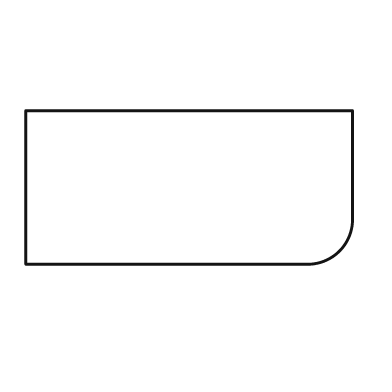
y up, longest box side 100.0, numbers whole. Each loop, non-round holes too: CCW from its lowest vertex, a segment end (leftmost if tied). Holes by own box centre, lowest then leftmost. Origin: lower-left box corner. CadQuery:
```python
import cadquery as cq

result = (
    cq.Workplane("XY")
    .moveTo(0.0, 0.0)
    .lineTo(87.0, 0.0)
    .threePointArc((96.0, 4.0), (100.0, 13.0))
    .lineTo(100.0, 47.0)
    .lineTo(0.0, 47.0)
    .close()
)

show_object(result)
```